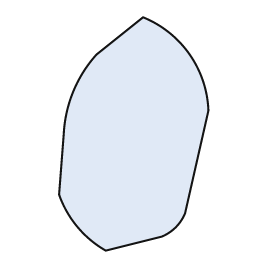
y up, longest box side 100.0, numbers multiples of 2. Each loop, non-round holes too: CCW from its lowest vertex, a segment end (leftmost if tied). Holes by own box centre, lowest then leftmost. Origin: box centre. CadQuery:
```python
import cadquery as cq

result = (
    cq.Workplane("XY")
    .moveTo(-12.0, -50.0)
    .lineTo(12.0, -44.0)
    .threePointArc((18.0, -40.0), (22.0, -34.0))
    .lineTo(32.0, 10.0)
    .threePointArc((24.0, 34.0), (4.0, 50.0))
    .lineTo(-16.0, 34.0)
    .threePointArc((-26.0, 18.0), (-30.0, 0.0))
    .lineTo(-32.0, -26.0)
    .threePointArc((-24.0, -40.0), (-12.0, -50.0))
    .close()
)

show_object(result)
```